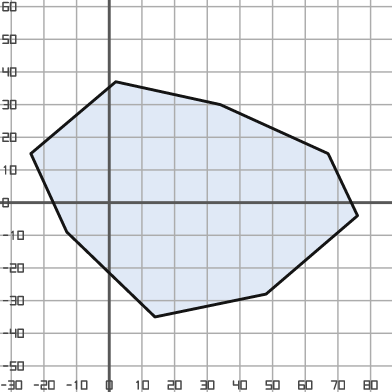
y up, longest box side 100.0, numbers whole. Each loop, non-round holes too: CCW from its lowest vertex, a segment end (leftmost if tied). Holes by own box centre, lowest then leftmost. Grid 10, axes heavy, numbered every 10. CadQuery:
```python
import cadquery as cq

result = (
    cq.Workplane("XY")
    .moveTo(14.0, -35.0)
    .lineTo(48.0, -28.0)
    .lineTo(76.0, -4.0)
    .lineTo(67.0, 15.0)
    .lineTo(34.0, 30.0)
    .lineTo(2.0, 37.0)
    .lineTo(-24.0, 15.0)
    .lineTo(-13.0, -9.0)
    .close()
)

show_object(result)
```